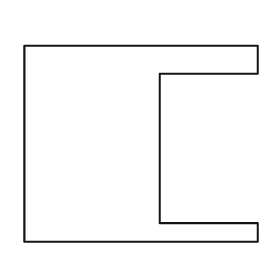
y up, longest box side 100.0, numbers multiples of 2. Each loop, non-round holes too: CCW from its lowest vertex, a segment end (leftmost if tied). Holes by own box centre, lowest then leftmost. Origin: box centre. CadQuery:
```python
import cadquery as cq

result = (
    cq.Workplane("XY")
    .moveTo(-50.0, -42.0)
    .lineTo(50.0, -42.0)
    .lineTo(50.0, -34.0)
    .lineTo(8.0, -34.0)
    .lineTo(8.0, 30.0)
    .lineTo(50.0, 30.0)
    .lineTo(50.0, 42.0)
    .lineTo(-50.0, 42.0)
    .close()
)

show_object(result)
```